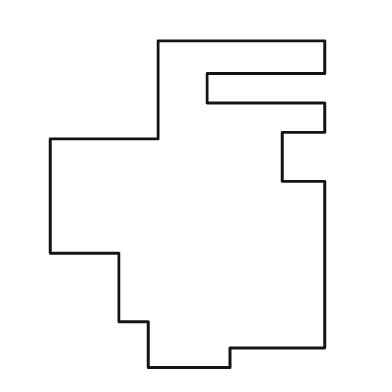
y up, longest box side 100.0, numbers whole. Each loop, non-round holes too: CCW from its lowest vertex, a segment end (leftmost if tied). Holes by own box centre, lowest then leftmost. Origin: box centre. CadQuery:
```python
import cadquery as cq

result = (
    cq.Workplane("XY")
    .moveTo(-12.0, -50.0)
    .lineTo(13.0, -50.0)
    .lineTo(13.0, -44.0)
    .lineTo(42.0, -44.0)
    .lineTo(42.0, 7.0)
    .lineTo(29.0, 7.0)
    .lineTo(29.0, 22.0)
    .lineTo(42.0, 22.0)
    .lineTo(42.0, 31.0)
    .lineTo(6.0, 31.0)
    .lineTo(6.0, 40.0)
    .lineTo(42.0, 40.0)
    .lineTo(42.0, 50.0)
    .lineTo(-9.0, 50.0)
    .lineTo(-9.0, 20.0)
    .lineTo(-42.0, 20.0)
    .lineTo(-42.0, -15.0)
    .lineTo(-21.0, -15.0)
    .lineTo(-21.0, -36.0)
    .lineTo(-12.0, -36.0)
    .close()
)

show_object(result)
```